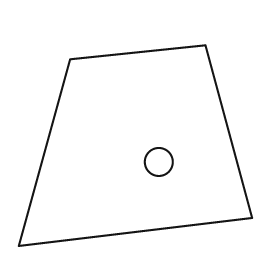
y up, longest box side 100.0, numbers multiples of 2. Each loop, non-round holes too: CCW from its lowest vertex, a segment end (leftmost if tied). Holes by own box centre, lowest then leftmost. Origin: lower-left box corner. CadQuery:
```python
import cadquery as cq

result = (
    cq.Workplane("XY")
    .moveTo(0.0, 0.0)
    .lineTo(100.0, 12.0)
    .lineTo(80.0, 86.0)
    .lineTo(22.0, 80.0)
    .close()
    .moveTo(60.0, 36.0)
    .circle(6.0)
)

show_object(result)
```